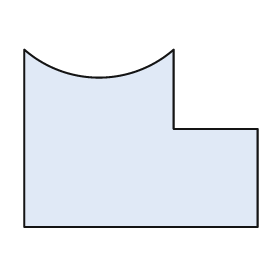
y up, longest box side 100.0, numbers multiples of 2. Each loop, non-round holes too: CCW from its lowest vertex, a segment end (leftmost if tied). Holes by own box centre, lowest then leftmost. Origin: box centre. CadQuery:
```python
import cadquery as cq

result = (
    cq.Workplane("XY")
    .moveTo(-50.0, -38.0)
    .lineTo(50.0, -38.0)
    .lineTo(50.0, 4.0)
    .lineTo(14.0, 4.0)
    .lineTo(14.0, 38.0)
    .threePointArc((-18.0, 26.0), (-50.0, 38.0))
    .close()
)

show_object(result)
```